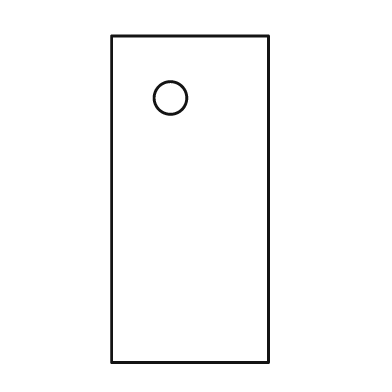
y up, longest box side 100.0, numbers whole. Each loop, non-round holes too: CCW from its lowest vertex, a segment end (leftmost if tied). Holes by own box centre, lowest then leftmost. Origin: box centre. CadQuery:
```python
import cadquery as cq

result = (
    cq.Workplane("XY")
    .moveTo(-24.0, -50.0)
    .lineTo(24.0, -50.0)
    .lineTo(24.0, 50.0)
    .lineTo(-24.0, 50.0)
    .close()
    .moveTo(-6.0, 31.0)
    .circle(5.0)
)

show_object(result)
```